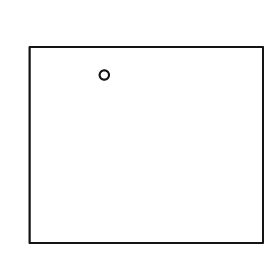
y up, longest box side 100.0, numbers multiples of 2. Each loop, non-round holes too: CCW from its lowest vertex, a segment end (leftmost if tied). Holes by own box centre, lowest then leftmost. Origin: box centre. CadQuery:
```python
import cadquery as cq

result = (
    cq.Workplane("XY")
    .moveTo(-50.0, -42.0)
    .lineTo(50.0, -42.0)
    .lineTo(50.0, 42.0)
    .lineTo(-50.0, 42.0)
    .close()
    .moveTo(-18.0, 30.0)
    .circle(2.0)
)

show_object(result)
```